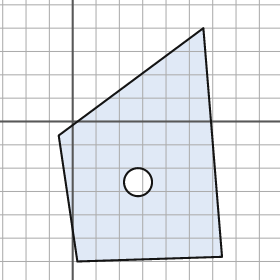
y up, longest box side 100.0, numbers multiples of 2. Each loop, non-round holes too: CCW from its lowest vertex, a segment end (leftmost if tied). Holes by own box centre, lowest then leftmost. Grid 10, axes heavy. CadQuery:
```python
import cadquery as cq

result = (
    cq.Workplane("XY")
    .moveTo(2.0, -60.0)
    .lineTo(64.0, -58.0)
    .lineTo(56.0, 40.0)
    .lineTo(-6.0, -6.0)
    .close()
    .moveTo(28.0, -26.0)
    .circle(6.0)
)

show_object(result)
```